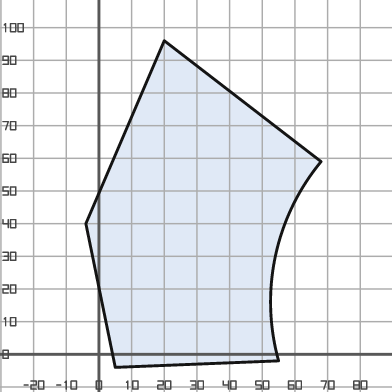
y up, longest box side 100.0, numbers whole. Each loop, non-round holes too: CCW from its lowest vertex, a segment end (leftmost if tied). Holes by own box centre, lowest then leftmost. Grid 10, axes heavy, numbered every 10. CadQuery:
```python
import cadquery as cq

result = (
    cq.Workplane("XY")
    .moveTo(5.0, -4.0)
    .lineTo(55.0, -2.0)
    .threePointArc((54.0, 30.0), (68.0, 59.0))
    .lineTo(20.0, 96.0)
    .lineTo(-4.0, 40.0)
    .close()
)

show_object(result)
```